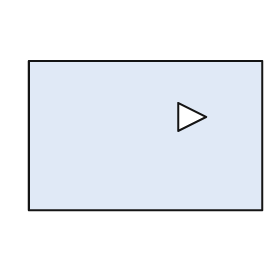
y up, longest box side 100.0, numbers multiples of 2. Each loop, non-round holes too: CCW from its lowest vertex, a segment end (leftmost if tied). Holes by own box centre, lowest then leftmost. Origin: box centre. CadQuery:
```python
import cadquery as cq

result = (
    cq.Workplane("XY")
    .moveTo(-50.0, -32.0)
    .lineTo(50.0, -32.0)
    .lineTo(50.0, 32.0)
    .lineTo(-50.0, 32.0)
    .close()
    .moveTo(14.0, 2.0)
    .lineTo(26.0, 8.0)
    .lineTo(14.0, 14.0)
    .close()
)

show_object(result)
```